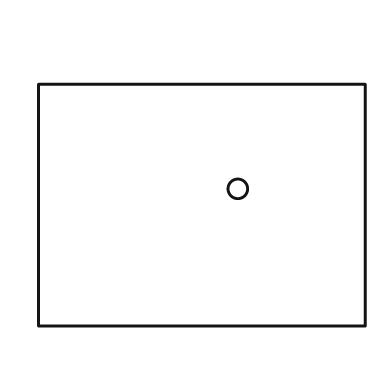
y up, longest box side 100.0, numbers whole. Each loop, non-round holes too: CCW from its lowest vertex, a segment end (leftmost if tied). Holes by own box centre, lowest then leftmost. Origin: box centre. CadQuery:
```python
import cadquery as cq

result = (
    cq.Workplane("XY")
    .moveTo(-50.0, -37.0)
    .lineTo(50.0, -37.0)
    .lineTo(50.0, 37.0)
    .lineTo(-50.0, 37.0)
    .close()
    .moveTo(11.0, 5.0)
    .circle(3.0)
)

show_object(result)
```